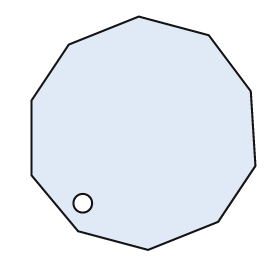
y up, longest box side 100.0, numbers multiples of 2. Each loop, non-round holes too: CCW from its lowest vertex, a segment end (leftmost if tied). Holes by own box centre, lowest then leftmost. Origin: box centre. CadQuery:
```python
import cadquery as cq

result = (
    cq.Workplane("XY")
    .moveTo(2.0, -50.0)
    .lineTo(32.0, -38.0)
    .lineTo(48.0, -14.0)
    .lineTo(46.0, 18.0)
    .lineTo(28.0, 42.0)
    .lineTo(-2.0, 50.0)
    .lineTo(-32.0, 38.0)
    .lineTo(-48.0, 14.0)
    .lineTo(-48.0, -18.0)
    .lineTo(-28.0, -42.0)
    .close()
    .moveTo(-26.0, -30.0)
    .circle(4.0)
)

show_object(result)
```